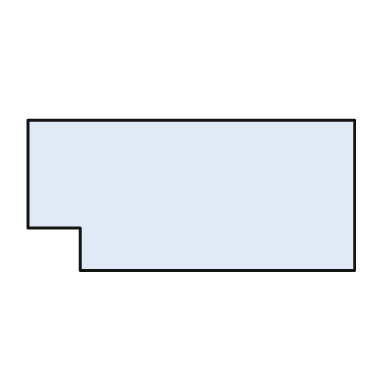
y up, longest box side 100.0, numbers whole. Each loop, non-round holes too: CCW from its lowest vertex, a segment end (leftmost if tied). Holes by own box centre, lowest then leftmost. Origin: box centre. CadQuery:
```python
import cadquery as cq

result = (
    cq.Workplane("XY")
    .moveTo(-34.0, -23.0)
    .lineTo(50.0, -23.0)
    .lineTo(50.0, 23.0)
    .lineTo(-50.0, 23.0)
    .lineTo(-50.0, -10.0)
    .lineTo(-34.0, -10.0)
    .close()
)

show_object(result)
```